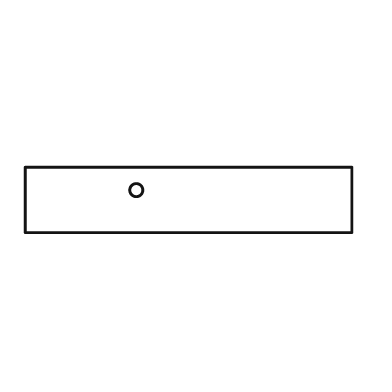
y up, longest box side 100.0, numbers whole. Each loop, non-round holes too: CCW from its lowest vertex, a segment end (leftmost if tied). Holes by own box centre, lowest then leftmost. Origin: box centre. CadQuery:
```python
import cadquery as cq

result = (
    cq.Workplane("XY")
    .moveTo(-50.0, -10.0)
    .lineTo(50.0, -10.0)
    .lineTo(50.0, 10.0)
    .lineTo(-50.0, 10.0)
    .close()
    .moveTo(-16.0, 3.0)
    .circle(2.0)
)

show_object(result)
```